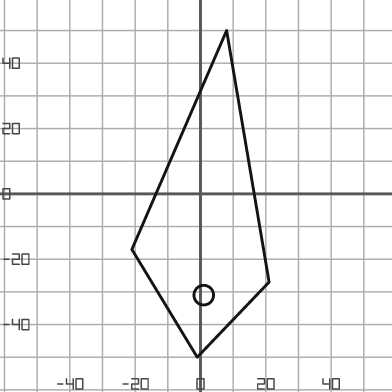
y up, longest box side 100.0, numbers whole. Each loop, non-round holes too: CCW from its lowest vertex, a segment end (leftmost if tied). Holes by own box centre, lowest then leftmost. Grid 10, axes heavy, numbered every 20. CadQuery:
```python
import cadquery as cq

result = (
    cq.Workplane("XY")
    .moveTo(-1.0, -50.0)
    .lineTo(21.0, -27.0)
    .lineTo(8.0, 50.0)
    .lineTo(-21.0, -17.0)
    .close()
    .moveTo(1.0, -31.0)
    .circle(3.0)
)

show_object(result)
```